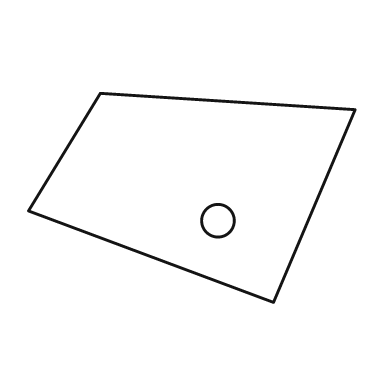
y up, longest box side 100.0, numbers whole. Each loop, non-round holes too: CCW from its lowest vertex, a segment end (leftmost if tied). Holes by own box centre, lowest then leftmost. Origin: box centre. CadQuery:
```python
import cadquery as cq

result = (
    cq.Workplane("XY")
    .moveTo(25.0, -32.0)
    .lineTo(50.0, 27.0)
    .lineTo(-28.0, 32.0)
    .lineTo(-50.0, -4.0)
    .close()
    .moveTo(8.0, -7.0)
    .circle(5.0)
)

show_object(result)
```